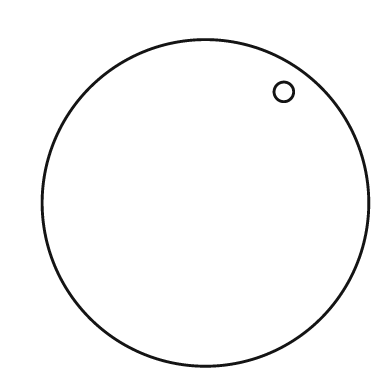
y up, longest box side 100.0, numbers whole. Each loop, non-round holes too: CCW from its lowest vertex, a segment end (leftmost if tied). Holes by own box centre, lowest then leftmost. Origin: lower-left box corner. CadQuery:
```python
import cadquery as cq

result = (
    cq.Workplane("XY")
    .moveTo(50.0, 50.0)
    .circle(50.0)
    .moveTo(74.0, 84.0)
    .circle(3.0)
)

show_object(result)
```